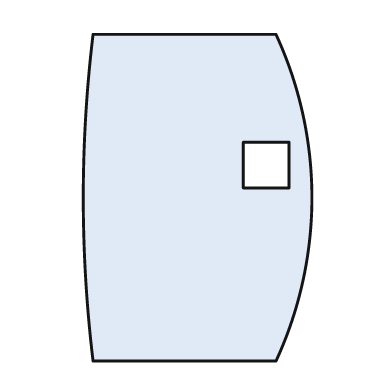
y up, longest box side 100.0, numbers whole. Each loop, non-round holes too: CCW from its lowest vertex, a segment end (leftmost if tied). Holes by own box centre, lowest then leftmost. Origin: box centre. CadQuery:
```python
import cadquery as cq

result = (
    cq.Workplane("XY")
    .moveTo(-32.0, -50.0)
    .lineTo(24.0, -50.0)
    .threePointArc((35.0, 0.0), (24.0, 50.0))
    .lineTo(-32.0, 50.0)
    .threePointArc((-35.0, 0.0), (-32.0, -50.0))
    .close()
    .moveTo(14.0, 3.0)
    .lineTo(28.0, 3.0)
    .lineTo(28.0, 17.0)
    .lineTo(14.0, 17.0)
    .close()
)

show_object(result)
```